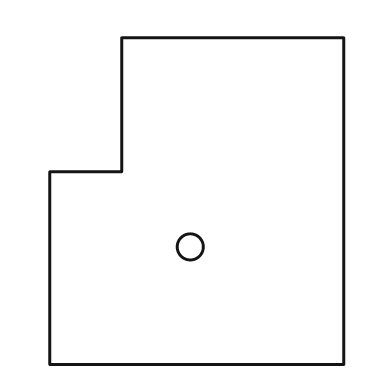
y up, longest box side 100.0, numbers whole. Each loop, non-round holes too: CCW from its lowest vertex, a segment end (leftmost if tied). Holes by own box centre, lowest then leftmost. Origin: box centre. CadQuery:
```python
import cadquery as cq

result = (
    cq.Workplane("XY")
    .moveTo(-45.0, -50.0)
    .lineTo(45.0, -50.0)
    .lineTo(45.0, 50.0)
    .lineTo(-23.0, 50.0)
    .lineTo(-23.0, 9.0)
    .lineTo(-45.0, 9.0)
    .close()
    .moveTo(-2.0, -14.0)
    .circle(4.0)
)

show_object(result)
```